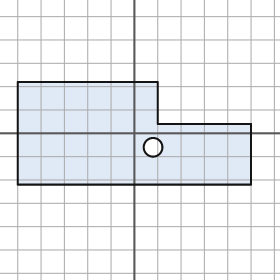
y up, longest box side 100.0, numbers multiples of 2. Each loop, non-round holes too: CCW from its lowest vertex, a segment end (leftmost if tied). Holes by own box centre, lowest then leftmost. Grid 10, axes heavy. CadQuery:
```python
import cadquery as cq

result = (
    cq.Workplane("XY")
    .moveTo(-50.0, -22.0)
    .lineTo(50.0, -22.0)
    .lineTo(50.0, 4.0)
    .lineTo(10.0, 4.0)
    .lineTo(10.0, 22.0)
    .lineTo(-50.0, 22.0)
    .close()
    .moveTo(8.0, -6.0)
    .circle(4.0)
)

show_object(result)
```